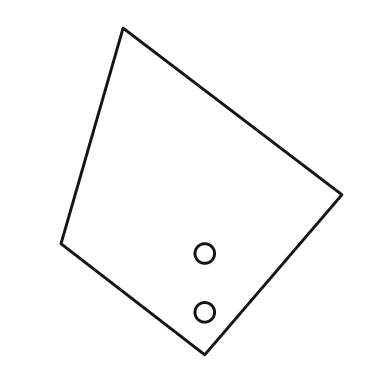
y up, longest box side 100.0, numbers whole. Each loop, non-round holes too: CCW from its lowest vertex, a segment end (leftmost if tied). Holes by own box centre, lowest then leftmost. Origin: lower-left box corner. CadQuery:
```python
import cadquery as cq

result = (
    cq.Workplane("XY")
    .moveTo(44.0, 0.0)
    .lineTo(86.0, 49.0)
    .lineTo(19.0, 100.0)
    .lineTo(0.0, 34.0)
    .close()
    .moveTo(44.0, 13.0)
    .circle(3.0)
    .moveTo(44.0, 31.0)
    .circle(3.0)
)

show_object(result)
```